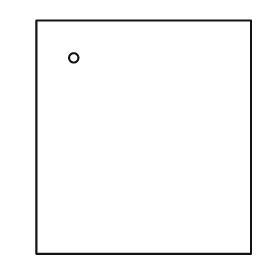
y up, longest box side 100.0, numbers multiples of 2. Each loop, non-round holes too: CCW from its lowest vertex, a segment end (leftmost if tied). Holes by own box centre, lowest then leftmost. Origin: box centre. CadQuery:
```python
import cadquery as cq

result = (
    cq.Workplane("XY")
    .moveTo(-46.0, -50.0)
    .lineTo(46.0, -50.0)
    .lineTo(46.0, 50.0)
    .lineTo(-46.0, 50.0)
    .close()
    .moveTo(-30.0, 34.0)
    .circle(2.0)
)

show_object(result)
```